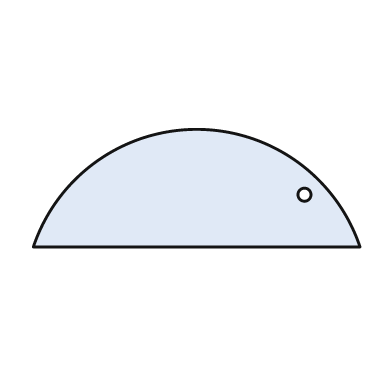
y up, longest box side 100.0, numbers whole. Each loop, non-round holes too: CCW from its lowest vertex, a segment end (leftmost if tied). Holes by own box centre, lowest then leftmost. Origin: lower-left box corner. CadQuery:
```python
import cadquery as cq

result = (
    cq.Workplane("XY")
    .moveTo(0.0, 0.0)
    .lineTo(100.0, 0.0)
    .threePointArc((50.0, 36.0), (0.0, 0.0))
    .close()
    .moveTo(83.0, 16.0)
    .circle(2.0)
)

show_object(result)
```